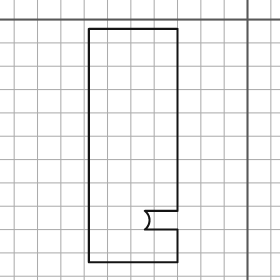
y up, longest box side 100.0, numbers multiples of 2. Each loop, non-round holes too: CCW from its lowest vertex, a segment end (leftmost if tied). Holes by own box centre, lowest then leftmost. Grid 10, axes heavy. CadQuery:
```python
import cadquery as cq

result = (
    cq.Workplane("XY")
    .moveTo(-68.0, -104.0)
    .lineTo(-30.0, -104.0)
    .lineTo(-30.0, -90.0)
    .lineTo(-44.0, -90.0)
    .threePointArc((-42.0, -86.0), (-44.0, -82.0))
    .lineTo(-30.0, -82.0)
    .lineTo(-30.0, -4.0)
    .lineTo(-68.0, -4.0)
    .close()
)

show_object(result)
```